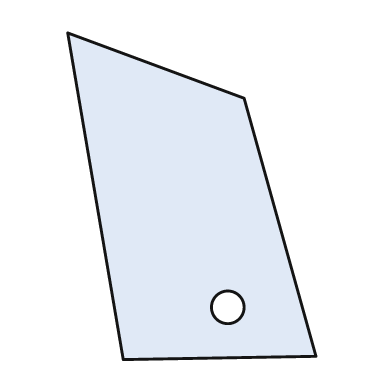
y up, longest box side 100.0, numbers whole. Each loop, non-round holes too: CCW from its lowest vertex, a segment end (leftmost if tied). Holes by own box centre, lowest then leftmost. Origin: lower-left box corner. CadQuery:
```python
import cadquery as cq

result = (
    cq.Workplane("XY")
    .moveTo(17.0, 0.0)
    .lineTo(76.0, 1.0)
    .lineTo(54.0, 80.0)
    .lineTo(0.0, 100.0)
    .close()
    .moveTo(49.0, 16.0)
    .circle(5.0)
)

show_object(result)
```